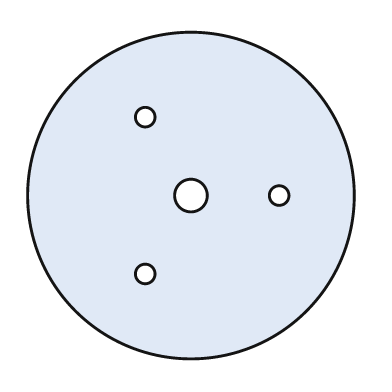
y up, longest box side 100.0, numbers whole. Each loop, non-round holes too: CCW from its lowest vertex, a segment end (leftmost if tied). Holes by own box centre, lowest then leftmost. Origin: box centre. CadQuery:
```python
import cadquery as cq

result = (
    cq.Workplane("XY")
    .moveTo(0.0, 0.0)
    .circle(50.0)
    .moveTo(-14.0, -24.0)
    .circle(3.0)
    .moveTo(0.0, 0.0)
    .circle(5.0)
    .moveTo(27.0, 0.0)
    .circle(3.0)
    .moveTo(-14.0, 24.0)
    .circle(3.0)
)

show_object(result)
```